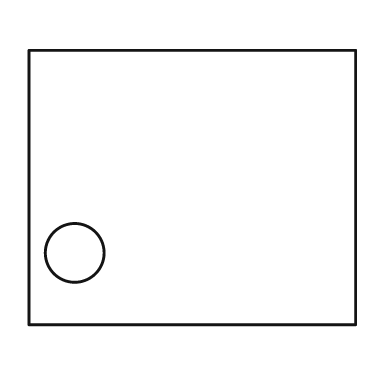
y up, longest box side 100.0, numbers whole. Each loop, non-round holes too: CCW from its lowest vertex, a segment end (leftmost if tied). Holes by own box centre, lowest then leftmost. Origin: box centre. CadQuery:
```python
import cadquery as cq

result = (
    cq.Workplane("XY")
    .moveTo(-50.0, -42.0)
    .lineTo(50.0, -42.0)
    .lineTo(50.0, 42.0)
    .lineTo(-50.0, 42.0)
    .close()
    .moveTo(-36.0, -20.0)
    .circle(9.0)
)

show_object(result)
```